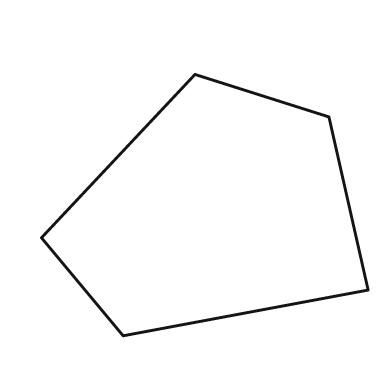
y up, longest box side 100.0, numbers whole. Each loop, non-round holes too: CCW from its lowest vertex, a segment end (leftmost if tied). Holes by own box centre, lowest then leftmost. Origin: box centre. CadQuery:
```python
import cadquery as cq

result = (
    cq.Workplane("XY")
    .moveTo(-25.0, -40.0)
    .lineTo(50.0, -26.0)
    .lineTo(38.0, 27.0)
    .lineTo(-3.0, 40.0)
    .lineTo(-50.0, -10.0)
    .close()
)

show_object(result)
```